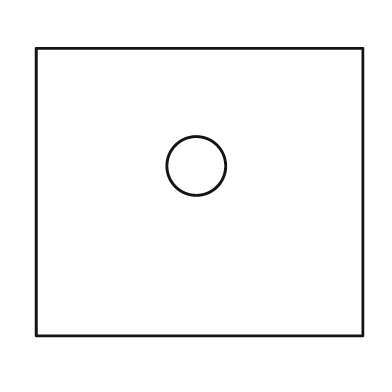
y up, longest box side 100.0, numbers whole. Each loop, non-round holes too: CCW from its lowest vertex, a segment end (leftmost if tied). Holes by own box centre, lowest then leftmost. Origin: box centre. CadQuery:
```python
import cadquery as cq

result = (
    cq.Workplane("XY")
    .moveTo(-50.0, -44.0)
    .lineTo(50.0, -44.0)
    .lineTo(50.0, 44.0)
    .lineTo(-50.0, 44.0)
    .close()
    .moveTo(-1.0, 8.0)
    .circle(9.0)
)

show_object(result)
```